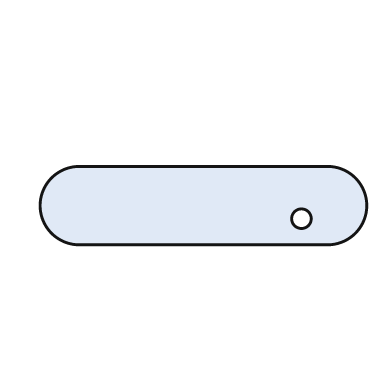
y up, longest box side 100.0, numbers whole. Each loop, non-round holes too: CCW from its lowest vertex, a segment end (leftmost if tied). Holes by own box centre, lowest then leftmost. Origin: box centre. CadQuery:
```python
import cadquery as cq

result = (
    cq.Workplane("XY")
    .moveTo(-38.0, -12.0)
    .lineTo(38.0, -12.0)
    .threePointArc((50.0, 0.0), (38.0, 12.0))
    .lineTo(-38.0, 12.0)
    .threePointArc((-50.0, 0.0), (-38.0, -12.0))
    .close()
    .moveTo(30.0, -4.0)
    .circle(3.0)
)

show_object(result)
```